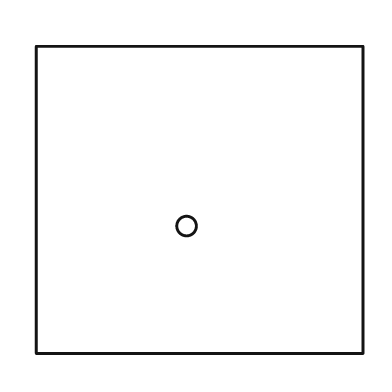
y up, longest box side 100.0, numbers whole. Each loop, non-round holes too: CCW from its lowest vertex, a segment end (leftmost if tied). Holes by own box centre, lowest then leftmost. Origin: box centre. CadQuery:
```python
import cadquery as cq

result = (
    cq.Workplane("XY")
    .moveTo(-50.0, -47.0)
    .lineTo(50.0, -47.0)
    .lineTo(50.0, 47.0)
    .lineTo(-50.0, 47.0)
    .close()
    .moveTo(-4.0, -8.0)
    .circle(3.0)
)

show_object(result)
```